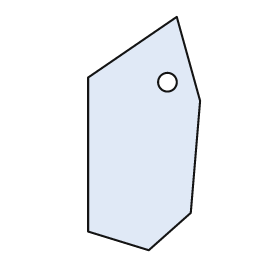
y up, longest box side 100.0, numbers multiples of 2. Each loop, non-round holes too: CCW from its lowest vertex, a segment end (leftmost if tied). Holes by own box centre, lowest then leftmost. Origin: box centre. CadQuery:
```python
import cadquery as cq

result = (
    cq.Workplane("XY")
    .moveTo(2.0, -50.0)
    .lineTo(20.0, -34.0)
    .lineTo(24.0, 14.0)
    .lineTo(14.0, 50.0)
    .lineTo(-24.0, 24.0)
    .lineTo(-24.0, -42.0)
    .close()
    .moveTo(10.0, 22.0)
    .circle(4.0)
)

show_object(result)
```